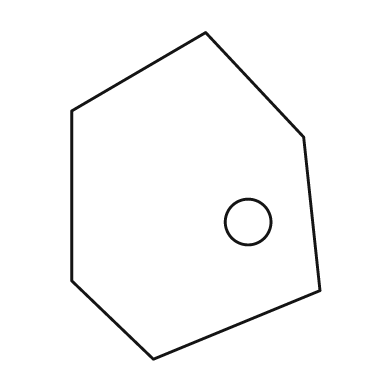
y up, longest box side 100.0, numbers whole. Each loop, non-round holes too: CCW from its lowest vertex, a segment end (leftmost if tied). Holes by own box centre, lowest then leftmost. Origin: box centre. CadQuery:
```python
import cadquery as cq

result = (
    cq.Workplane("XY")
    .moveTo(-13.0, -50.0)
    .lineTo(38.0, -29.0)
    .lineTo(33.0, 18.0)
    .lineTo(3.0, 50.0)
    .lineTo(-38.0, 26.0)
    .lineTo(-38.0, -26.0)
    .close()
    .moveTo(16.0, -8.0)
    .circle(7.0)
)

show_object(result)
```